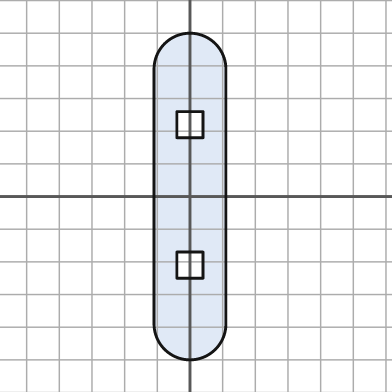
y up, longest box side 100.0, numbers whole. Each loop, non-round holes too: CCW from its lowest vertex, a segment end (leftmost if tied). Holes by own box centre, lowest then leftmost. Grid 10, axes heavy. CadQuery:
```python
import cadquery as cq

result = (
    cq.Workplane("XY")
    .moveTo(-11.0, -39.0)
    .threePointArc((0.0, -50.0), (11.0, -39.0))
    .lineTo(11.0, 39.0)
    .threePointArc((0.0, 50.0), (-11.0, 39.0))
    .close()
    .moveTo(-4.0, -25.0)
    .lineTo(4.0, -25.0)
    .lineTo(4.0, -17.0)
    .lineTo(-4.0, -17.0)
    .close()
    .moveTo(-4.0, 18.0)
    .lineTo(4.0, 18.0)
    .lineTo(4.0, 26.0)
    .lineTo(-4.0, 26.0)
    .close()
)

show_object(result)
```